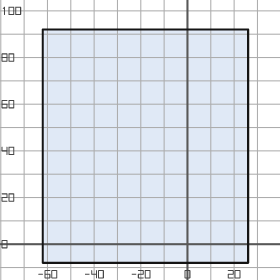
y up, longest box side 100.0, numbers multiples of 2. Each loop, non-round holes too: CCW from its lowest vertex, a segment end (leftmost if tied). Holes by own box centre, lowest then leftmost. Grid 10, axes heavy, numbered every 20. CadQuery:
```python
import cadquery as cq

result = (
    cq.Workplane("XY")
    .moveTo(-62.0, -8.0)
    .lineTo(26.0, -8.0)
    .lineTo(26.0, 92.0)
    .lineTo(-62.0, 92.0)
    .close()
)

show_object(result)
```